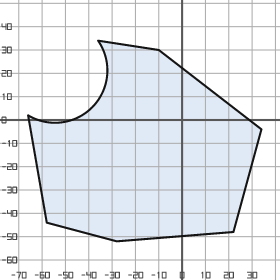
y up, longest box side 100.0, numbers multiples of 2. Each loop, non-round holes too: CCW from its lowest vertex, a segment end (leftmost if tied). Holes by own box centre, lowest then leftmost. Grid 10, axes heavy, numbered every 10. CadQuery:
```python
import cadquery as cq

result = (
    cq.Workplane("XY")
    .moveTo(-28.0, -52.0)
    .lineTo(22.0, -48.0)
    .lineTo(34.0, -4.0)
    .lineTo(-10.0, 30.0)
    .lineTo(-36.0, 34.0)
    .threePointArc((-38.0, 6.0), (-66.0, 2.0))
    .lineTo(-58.0, -44.0)
    .close()
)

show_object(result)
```